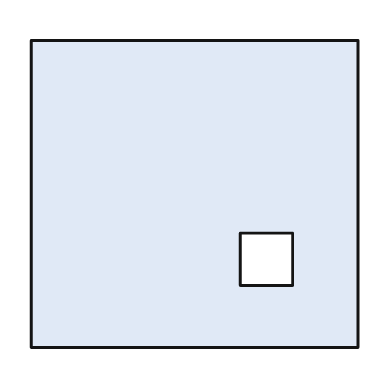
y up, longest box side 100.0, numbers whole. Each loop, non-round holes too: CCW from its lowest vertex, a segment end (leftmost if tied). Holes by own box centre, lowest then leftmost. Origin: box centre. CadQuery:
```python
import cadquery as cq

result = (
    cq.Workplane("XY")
    .moveTo(-50.0, -47.0)
    .lineTo(50.0, -47.0)
    .lineTo(50.0, 47.0)
    .lineTo(-50.0, 47.0)
    .close()
    .moveTo(14.0, -28.0)
    .lineTo(30.0, -28.0)
    .lineTo(30.0, -12.0)
    .lineTo(14.0, -12.0)
    .close()
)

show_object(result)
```